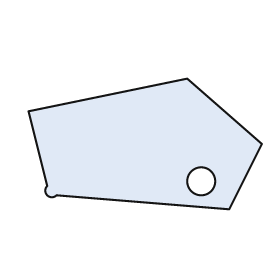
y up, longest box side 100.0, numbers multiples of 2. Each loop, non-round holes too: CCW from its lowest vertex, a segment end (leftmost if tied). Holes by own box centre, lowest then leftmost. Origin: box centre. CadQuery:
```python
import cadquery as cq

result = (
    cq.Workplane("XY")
    .moveTo(36.0, -28.0)
    .lineTo(50.0, 0.0)
    .lineTo(18.0, 28.0)
    .lineTo(-50.0, 14.0)
    .lineTo(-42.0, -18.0)
    .threePointArc((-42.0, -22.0), (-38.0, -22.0))
    .close()
    .moveTo(24.0, -16.0)
    .circle(6.0)
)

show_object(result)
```